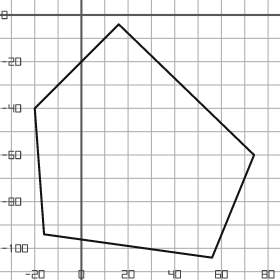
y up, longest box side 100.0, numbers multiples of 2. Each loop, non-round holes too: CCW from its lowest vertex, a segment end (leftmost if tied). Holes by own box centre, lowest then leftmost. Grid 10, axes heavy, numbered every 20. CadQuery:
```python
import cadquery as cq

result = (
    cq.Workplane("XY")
    .moveTo(56.0, -104.0)
    .lineTo(74.0, -60.0)
    .lineTo(16.0, -4.0)
    .lineTo(-20.0, -40.0)
    .lineTo(-16.0, -94.0)
    .close()
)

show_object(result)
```